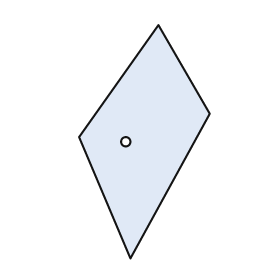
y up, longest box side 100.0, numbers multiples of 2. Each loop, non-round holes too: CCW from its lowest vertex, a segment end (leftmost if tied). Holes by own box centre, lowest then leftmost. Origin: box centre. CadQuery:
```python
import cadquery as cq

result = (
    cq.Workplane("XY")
    .moveTo(-6.0, -50.0)
    .lineTo(28.0, 12.0)
    .lineTo(6.0, 50.0)
    .lineTo(-28.0, 2.0)
    .close()
    .moveTo(-8.0, 0.0)
    .circle(2.0)
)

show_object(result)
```